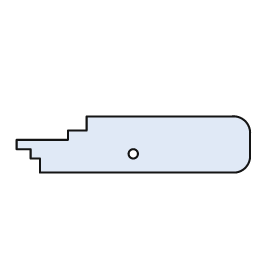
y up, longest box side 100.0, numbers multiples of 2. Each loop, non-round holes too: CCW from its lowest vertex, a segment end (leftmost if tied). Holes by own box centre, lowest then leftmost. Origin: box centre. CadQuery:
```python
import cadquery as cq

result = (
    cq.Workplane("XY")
    .moveTo(-40.0, -12.0)
    .lineTo(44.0, -12.0)
    .threePointArc((48.0, -10.0), (50.0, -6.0))
    .lineTo(50.0, 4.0)
    .threePointArc((48.0, 10.0), (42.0, 12.0))
    .lineTo(-20.0, 12.0)
    .lineTo(-20.0, 6.0)
    .lineTo(-28.0, 6.0)
    .lineTo(-28.0, 2.0)
    .lineTo(-50.0, 2.0)
    .lineTo(-50.0, -2.0)
    .lineTo(-44.0, -2.0)
    .lineTo(-44.0, -6.0)
    .lineTo(-40.0, -6.0)
    .close()
    .moveTo(0.0, -4.0)
    .circle(2.0)
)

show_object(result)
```